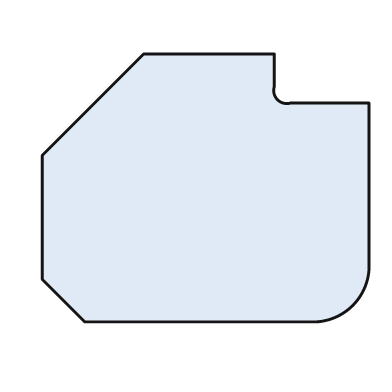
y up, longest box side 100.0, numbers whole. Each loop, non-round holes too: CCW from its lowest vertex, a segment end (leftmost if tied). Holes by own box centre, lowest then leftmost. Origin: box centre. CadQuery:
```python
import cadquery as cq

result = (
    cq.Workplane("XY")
    .moveTo(-37.0, -41.0)
    .lineTo(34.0, -41.0)
    .threePointArc((45.0, -36.0), (50.0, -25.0))
    .lineTo(50.0, 26.0)
    .lineTo(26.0, 26.0)
    .threePointArc((22.0, 27.0), (21.0, 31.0))
    .lineTo(21.0, 41.0)
    .lineTo(-19.0, 41.0)
    .lineTo(-50.0, 10.0)
    .lineTo(-50.0, -28.0)
    .close()
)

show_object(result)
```